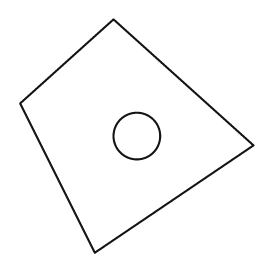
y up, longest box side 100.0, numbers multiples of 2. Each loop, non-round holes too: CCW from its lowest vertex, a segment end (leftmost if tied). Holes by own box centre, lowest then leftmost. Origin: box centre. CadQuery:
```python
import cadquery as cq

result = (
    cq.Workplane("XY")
    .moveTo(-18.0, -50.0)
    .lineTo(50.0, -4.0)
    .lineTo(-10.0, 50.0)
    .lineTo(-50.0, 14.0)
    .close()
    .moveTo(0.0, 0.0)
    .circle(10.0)
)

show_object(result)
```